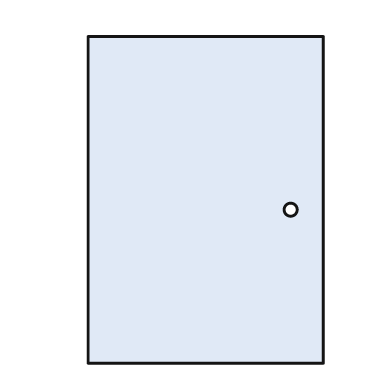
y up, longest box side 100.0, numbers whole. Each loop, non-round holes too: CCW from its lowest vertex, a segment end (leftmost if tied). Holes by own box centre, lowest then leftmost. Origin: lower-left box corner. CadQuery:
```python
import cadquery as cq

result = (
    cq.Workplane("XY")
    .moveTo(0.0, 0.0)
    .lineTo(72.0, 0.0)
    .lineTo(72.0, 100.0)
    .lineTo(0.0, 100.0)
    .close()
    .moveTo(62.0, 47.0)
    .circle(2.0)
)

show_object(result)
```